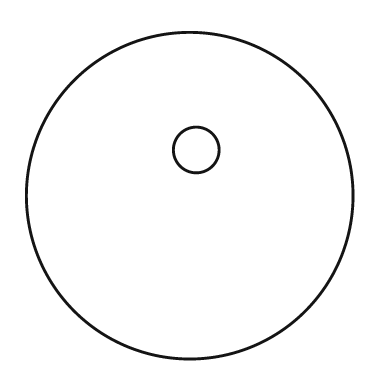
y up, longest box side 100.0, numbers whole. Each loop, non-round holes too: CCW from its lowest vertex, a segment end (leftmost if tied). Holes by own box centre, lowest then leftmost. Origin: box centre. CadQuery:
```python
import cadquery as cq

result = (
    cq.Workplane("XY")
    .moveTo(0.0, 0.0)
    .circle(50.0)
    .moveTo(2.0, 14.0)
    .circle(7.0)
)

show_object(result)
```